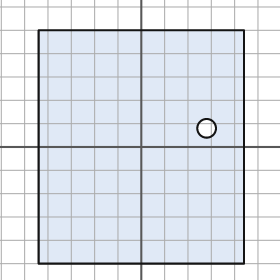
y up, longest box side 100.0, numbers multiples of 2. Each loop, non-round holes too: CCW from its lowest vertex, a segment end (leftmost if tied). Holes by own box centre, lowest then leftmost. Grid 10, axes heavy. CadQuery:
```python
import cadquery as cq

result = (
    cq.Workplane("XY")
    .moveTo(-44.0, -50.0)
    .lineTo(44.0, -50.0)
    .lineTo(44.0, 50.0)
    .lineTo(-44.0, 50.0)
    .close()
    .moveTo(28.0, 8.0)
    .circle(4.0)
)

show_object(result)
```